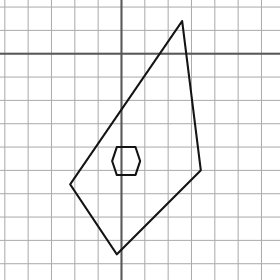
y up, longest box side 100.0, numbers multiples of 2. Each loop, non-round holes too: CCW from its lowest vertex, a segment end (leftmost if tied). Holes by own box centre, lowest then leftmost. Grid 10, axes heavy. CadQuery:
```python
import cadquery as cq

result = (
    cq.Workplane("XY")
    .moveTo(-2.0, -86.0)
    .lineTo(34.0, -50.0)
    .lineTo(26.0, 14.0)
    .lineTo(-22.0, -56.0)
    .close()
    .moveTo(-2.0, -52.0)
    .lineTo(6.0, -52.0)
    .lineTo(8.0, -46.0)
    .lineTo(6.0, -40.0)
    .lineTo(-2.0, -40.0)
    .lineTo(-4.0, -46.0)
    .close()
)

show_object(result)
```